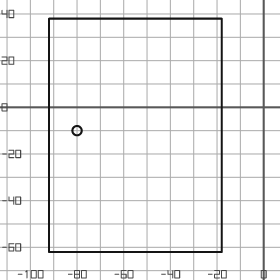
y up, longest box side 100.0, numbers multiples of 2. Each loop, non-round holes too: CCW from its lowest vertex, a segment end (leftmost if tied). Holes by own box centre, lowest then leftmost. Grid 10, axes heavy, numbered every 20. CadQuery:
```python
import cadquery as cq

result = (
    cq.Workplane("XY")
    .moveTo(-92.0, -62.0)
    .lineTo(-18.0, -62.0)
    .lineTo(-18.0, 38.0)
    .lineTo(-92.0, 38.0)
    .close()
    .moveTo(-80.0, -10.0)
    .circle(2.0)
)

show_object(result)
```